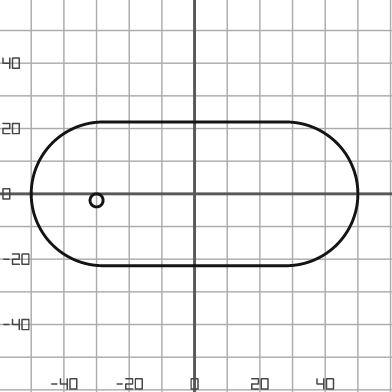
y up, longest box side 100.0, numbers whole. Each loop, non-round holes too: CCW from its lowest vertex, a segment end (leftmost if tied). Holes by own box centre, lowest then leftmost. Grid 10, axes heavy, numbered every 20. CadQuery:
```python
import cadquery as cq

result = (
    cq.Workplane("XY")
    .moveTo(-28.0, -22.0)
    .lineTo(28.0, -22.0)
    .threePointArc((50.0, 0.0), (28.0, 22.0))
    .lineTo(-28.0, 22.0)
    .threePointArc((-50.0, 0.0), (-28.0, -22.0))
    .close()
    .moveTo(-30.0, -2.0)
    .circle(2.0)
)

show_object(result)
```